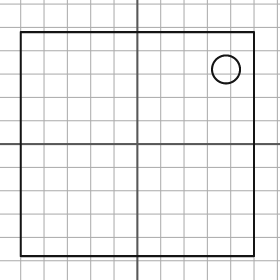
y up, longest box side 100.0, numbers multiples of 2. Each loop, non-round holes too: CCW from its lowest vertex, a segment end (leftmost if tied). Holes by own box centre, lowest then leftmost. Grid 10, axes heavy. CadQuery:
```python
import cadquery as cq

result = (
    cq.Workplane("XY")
    .moveTo(-50.0, -48.0)
    .lineTo(50.0, -48.0)
    .lineTo(50.0, 48.0)
    .lineTo(-50.0, 48.0)
    .close()
    .moveTo(38.0, 32.0)
    .circle(6.0)
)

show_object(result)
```